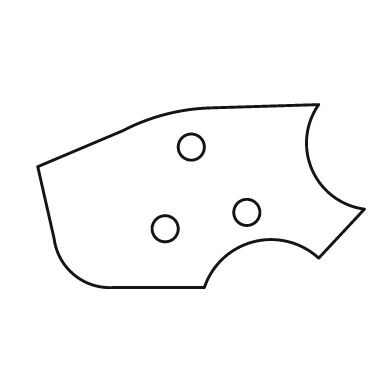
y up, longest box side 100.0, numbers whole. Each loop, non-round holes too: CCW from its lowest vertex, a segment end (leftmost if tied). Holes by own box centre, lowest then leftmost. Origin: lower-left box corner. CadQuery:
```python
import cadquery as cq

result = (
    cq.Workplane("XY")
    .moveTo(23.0, 0.0)
    .lineTo(51.0, 0.0)
    .threePointArc((66.0, 14.0), (86.0, 9.0))
    .lineTo(100.0, 24.0)
    .threePointArc((84.0, 36.0), (86.0, 56.0))
    .lineTo(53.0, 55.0)
    .threePointArc((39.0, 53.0), (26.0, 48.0))
    .lineTo(0.0, 37.0)
    .lineTo(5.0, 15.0)
    .threePointArc((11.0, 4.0), (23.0, 0.0))
    .close()
    .moveTo(39.0, 18.0)
    .circle(4.0)
    .moveTo(64.0, 23.0)
    .circle(4.0)
    .moveTo(47.0, 43.0)
    .circle(4.0)
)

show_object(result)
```